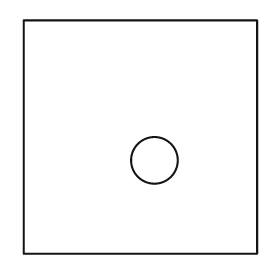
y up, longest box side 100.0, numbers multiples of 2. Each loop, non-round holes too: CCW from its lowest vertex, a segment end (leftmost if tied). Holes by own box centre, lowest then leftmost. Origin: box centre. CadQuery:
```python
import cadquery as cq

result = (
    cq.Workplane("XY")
    .moveTo(-50.0, -50.0)
    .lineTo(50.0, -50.0)
    .lineTo(50.0, 50.0)
    .lineTo(-50.0, 50.0)
    .close()
    .moveTo(6.0, -10.0)
    .circle(10.0)
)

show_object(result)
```